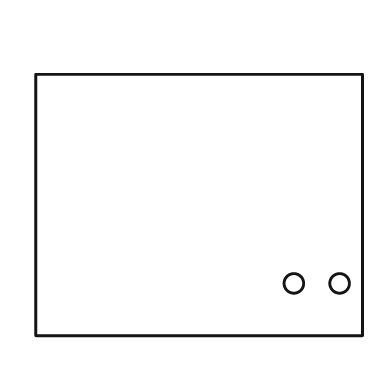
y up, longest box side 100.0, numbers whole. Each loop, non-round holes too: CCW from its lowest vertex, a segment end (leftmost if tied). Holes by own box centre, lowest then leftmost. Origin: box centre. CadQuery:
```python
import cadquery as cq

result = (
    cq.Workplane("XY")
    .moveTo(-50.0, -40.0)
    .lineTo(50.0, -40.0)
    .lineTo(50.0, 40.0)
    .lineTo(-50.0, 40.0)
    .close()
    .moveTo(29.0, -24.0)
    .circle(3.0)
    .moveTo(43.0, -24.0)
    .circle(3.0)
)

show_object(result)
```